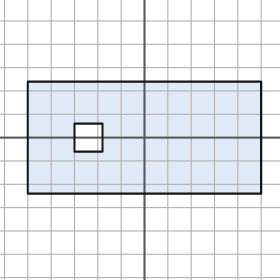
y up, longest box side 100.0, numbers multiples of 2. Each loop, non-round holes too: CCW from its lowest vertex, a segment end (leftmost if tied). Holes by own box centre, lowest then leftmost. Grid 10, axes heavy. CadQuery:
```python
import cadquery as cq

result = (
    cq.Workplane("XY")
    .moveTo(-50.0, -24.0)
    .lineTo(50.0, -24.0)
    .lineTo(50.0, 24.0)
    .lineTo(-50.0, 24.0)
    .close()
    .moveTo(-30.0, -6.0)
    .lineTo(-18.0, -6.0)
    .lineTo(-18.0, 6.0)
    .lineTo(-30.0, 6.0)
    .close()
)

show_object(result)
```